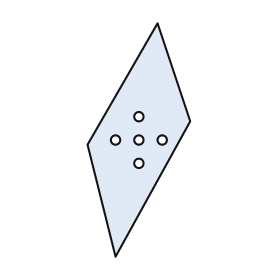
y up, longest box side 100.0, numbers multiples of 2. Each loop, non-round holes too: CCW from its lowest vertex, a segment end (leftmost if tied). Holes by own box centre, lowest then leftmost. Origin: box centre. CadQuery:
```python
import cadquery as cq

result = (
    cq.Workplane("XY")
    .moveTo(-10.0, -50.0)
    .lineTo(22.0, 8.0)
    .lineTo(8.0, 50.0)
    .lineTo(-22.0, -2.0)
    .close()
    .moveTo(0.0, -10.0)
    .circle(2.0)
    .moveTo(-10.0, 0.0)
    .circle(2.0)
    .moveTo(0.0, 0.0)
    .circle(2.0)
    .moveTo(10.0, 0.0)
    .circle(2.0)
    .moveTo(0.0, 10.0)
    .circle(2.0)
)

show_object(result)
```